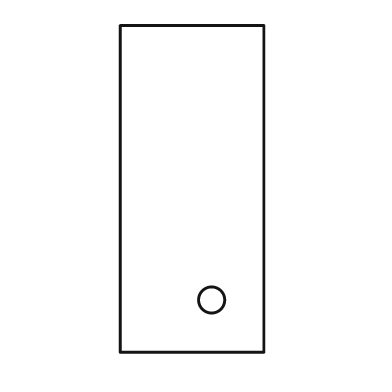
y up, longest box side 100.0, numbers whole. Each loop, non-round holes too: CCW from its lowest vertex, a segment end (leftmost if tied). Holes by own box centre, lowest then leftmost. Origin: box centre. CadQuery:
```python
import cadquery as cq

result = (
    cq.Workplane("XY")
    .moveTo(-22.0, -50.0)
    .lineTo(22.0, -50.0)
    .lineTo(22.0, 50.0)
    .lineTo(-22.0, 50.0)
    .close()
    .moveTo(6.0, -34.0)
    .circle(4.0)
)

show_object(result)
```